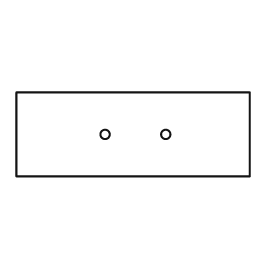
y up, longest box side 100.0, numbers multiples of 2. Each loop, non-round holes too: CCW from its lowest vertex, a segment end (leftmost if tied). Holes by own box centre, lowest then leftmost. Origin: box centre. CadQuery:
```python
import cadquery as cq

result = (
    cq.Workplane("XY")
    .moveTo(-50.0, -18.0)
    .lineTo(50.0, -18.0)
    .lineTo(50.0, 18.0)
    .lineTo(-50.0, 18.0)
    .close()
    .moveTo(-12.0, 0.0)
    .circle(2.0)
    .moveTo(14.0, 0.0)
    .circle(2.0)
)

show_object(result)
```